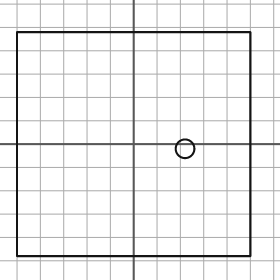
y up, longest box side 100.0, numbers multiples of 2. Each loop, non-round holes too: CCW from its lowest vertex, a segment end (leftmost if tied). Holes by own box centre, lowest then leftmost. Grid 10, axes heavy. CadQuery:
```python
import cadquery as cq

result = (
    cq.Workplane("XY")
    .moveTo(-50.0, -48.0)
    .lineTo(50.0, -48.0)
    .lineTo(50.0, 48.0)
    .lineTo(-50.0, 48.0)
    .close()
    .moveTo(22.0, -2.0)
    .circle(4.0)
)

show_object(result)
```